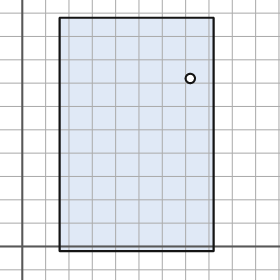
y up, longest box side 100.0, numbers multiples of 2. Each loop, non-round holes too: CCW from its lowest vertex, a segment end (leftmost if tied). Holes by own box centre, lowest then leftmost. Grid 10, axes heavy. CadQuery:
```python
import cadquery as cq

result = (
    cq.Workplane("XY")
    .moveTo(16.0, -2.0)
    .lineTo(82.0, -2.0)
    .lineTo(82.0, 98.0)
    .lineTo(16.0, 98.0)
    .close()
    .moveTo(72.0, 72.0)
    .circle(2.0)
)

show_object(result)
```